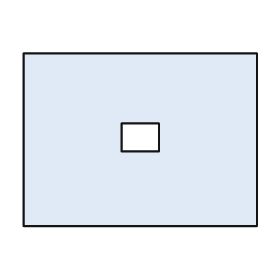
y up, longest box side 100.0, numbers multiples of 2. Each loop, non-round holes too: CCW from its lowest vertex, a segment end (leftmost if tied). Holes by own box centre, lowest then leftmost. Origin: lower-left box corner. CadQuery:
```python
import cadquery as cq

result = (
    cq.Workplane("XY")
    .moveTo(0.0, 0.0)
    .lineTo(100.0, 0.0)
    .lineTo(100.0, 74.0)
    .lineTo(0.0, 74.0)
    .close()
    .moveTo(42.0, 32.0)
    .lineTo(58.0, 32.0)
    .lineTo(58.0, 44.0)
    .lineTo(42.0, 44.0)
    .close()
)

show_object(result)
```